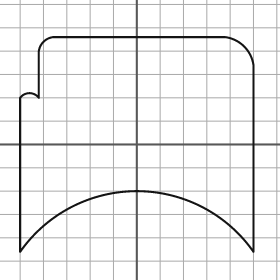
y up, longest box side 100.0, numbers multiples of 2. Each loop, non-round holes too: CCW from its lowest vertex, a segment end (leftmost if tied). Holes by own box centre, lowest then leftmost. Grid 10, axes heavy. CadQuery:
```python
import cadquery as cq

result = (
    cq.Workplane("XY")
    .moveTo(-50.0, -46.0)
    .threePointArc((0.0, -20.0), (50.0, -46.0))
    .lineTo(50.0, 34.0)
    .threePointArc((46.0, 42.0), (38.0, 46.0))
    .lineTo(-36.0, 46.0)
    .threePointArc((-40.0, 44.0), (-42.0, 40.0))
    .lineTo(-42.0, 20.0)
    .threePointArc((-46.0, 22.0), (-50.0, 20.0))
    .close()
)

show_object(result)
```